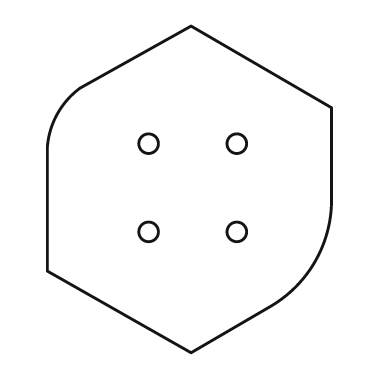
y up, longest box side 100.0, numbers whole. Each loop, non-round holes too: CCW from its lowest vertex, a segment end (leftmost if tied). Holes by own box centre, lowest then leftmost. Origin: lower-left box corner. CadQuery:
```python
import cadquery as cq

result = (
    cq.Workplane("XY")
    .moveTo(44.0, 0.0)
    .lineTo(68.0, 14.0)
    .threePointArc((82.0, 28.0), (87.0, 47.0))
    .lineTo(87.0, 75.0)
    .lineTo(44.0, 100.0)
    .lineTo(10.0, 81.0)
    .threePointArc((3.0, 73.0), (0.0, 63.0))
    .lineTo(0.0, 25.0)
    .close()
    .moveTo(31.0, 37.0)
    .circle(3.0)
    .moveTo(58.0, 37.0)
    .circle(3.0)
    .moveTo(31.0, 64.0)
    .circle(3.0)
    .moveTo(58.0, 64.0)
    .circle(3.0)
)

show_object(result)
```